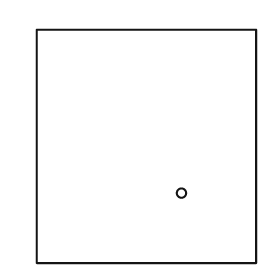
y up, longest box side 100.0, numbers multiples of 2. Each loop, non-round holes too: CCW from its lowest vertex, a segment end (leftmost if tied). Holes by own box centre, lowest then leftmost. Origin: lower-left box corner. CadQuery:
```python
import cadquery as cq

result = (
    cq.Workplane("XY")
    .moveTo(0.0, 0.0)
    .lineTo(94.0, 0.0)
    .lineTo(94.0, 100.0)
    .lineTo(0.0, 100.0)
    .close()
    .moveTo(62.0, 30.0)
    .circle(2.0)
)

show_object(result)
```